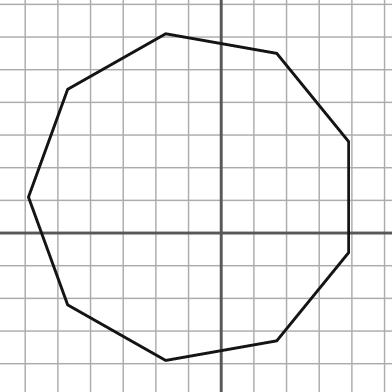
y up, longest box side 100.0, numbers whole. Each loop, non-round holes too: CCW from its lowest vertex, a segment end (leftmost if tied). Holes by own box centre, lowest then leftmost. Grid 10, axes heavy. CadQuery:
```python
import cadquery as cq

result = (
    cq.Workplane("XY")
    .moveTo(-17.0, -39.0)
    .lineTo(17.0, -33.0)
    .lineTo(39.0, -6.0)
    .lineTo(39.0, 28.0)
    .lineTo(17.0, 55.0)
    .lineTo(-17.0, 61.0)
    .lineTo(-47.0, 44.0)
    .lineTo(-59.0, 11.0)
    .lineTo(-47.0, -22.0)
    .close()
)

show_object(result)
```